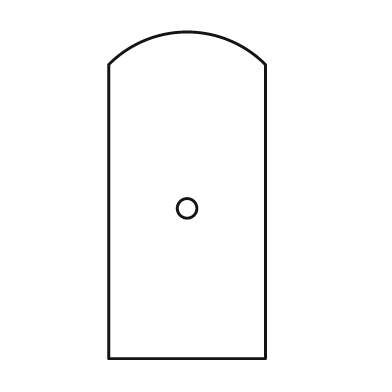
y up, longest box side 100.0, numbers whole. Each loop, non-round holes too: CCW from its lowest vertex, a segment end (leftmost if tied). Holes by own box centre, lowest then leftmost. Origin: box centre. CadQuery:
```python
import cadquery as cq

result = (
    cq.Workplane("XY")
    .moveTo(-24.0, -50.0)
    .lineTo(24.0, -50.0)
    .lineTo(24.0, 40.0)
    .threePointArc((0.0, 50.0), (-24.0, 40.0))
    .close()
    .moveTo(0.0, -4.0)
    .circle(3.0)
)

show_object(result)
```